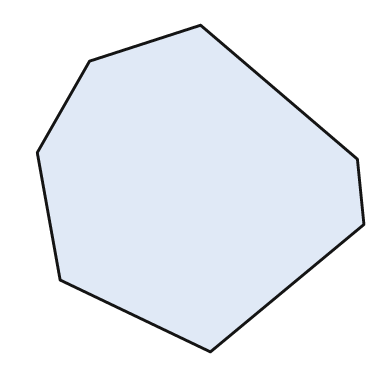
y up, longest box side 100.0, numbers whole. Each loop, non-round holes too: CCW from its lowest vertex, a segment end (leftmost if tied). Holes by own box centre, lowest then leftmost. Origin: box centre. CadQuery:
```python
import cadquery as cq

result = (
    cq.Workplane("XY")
    .moveTo(3.0, -50.0)
    .lineTo(50.0, -11.0)
    .lineTo(48.0, 9.0)
    .lineTo(0.0, 50.0)
    .lineTo(-34.0, 39.0)
    .lineTo(-50.0, 11.0)
    .lineTo(-43.0, -28.0)
    .close()
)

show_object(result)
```